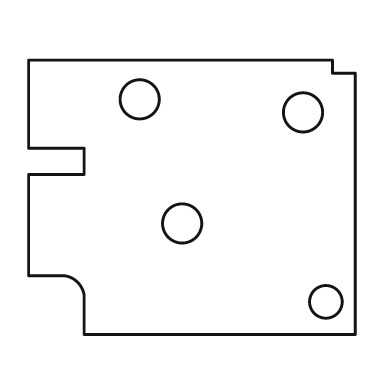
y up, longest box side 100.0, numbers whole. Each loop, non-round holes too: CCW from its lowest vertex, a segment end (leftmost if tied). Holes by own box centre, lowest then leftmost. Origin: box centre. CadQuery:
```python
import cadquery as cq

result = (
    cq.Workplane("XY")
    .moveTo(-33.0, -42.0)
    .lineTo(50.0, -42.0)
    .lineTo(50.0, 38.0)
    .lineTo(43.0, 38.0)
    .lineTo(43.0, 42.0)
    .lineTo(-50.0, 42.0)
    .lineTo(-50.0, 15.0)
    .lineTo(-33.0, 15.0)
    .lineTo(-33.0, 7.0)
    .lineTo(-50.0, 7.0)
    .lineTo(-50.0, -24.0)
    .lineTo(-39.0, -24.0)
    .threePointArc((-35.0, -26.0), (-33.0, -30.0))
    .close()
    .moveTo(41.0, -32.0)
    .circle(5.0)
    .moveTo(-3.0, -8.0)
    .circle(6.0)
    .moveTo(34.0, 26.0)
    .circle(6.0)
    .moveTo(-16.0, 30.0)
    .circle(6.0)
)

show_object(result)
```